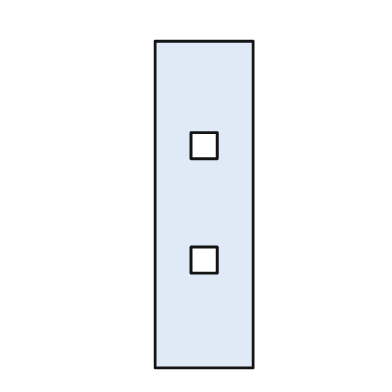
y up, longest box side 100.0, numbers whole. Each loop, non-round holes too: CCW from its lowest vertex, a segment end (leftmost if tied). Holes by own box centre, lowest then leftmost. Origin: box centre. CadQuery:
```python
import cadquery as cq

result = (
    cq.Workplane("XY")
    .moveTo(-15.0, -50.0)
    .lineTo(15.0, -50.0)
    .lineTo(15.0, 50.0)
    .lineTo(-15.0, 50.0)
    .close()
    .moveTo(-4.0, -21.0)
    .lineTo(4.0, -21.0)
    .lineTo(4.0, -13.0)
    .lineTo(-4.0, -13.0)
    .close()
    .moveTo(-4.0, 14.0)
    .lineTo(4.0, 14.0)
    .lineTo(4.0, 22.0)
    .lineTo(-4.0, 22.0)
    .close()
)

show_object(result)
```